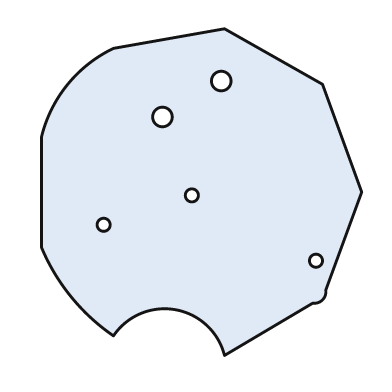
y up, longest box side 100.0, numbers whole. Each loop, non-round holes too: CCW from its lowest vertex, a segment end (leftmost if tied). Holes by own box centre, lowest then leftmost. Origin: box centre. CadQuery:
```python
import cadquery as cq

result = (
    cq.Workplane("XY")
    .moveTo(7.0, -50.0)
    .lineTo(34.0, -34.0)
    .threePointArc((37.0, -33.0), (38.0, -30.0))
    .lineTo(49.0, 0.0)
    .lineTo(37.0, 33.0)
    .lineTo(7.0, 50.0)
    .lineTo(-27.0, 44.0)
    .threePointArc((-41.0, 33.0), (-49.0, 17.0))
    .lineTo(-49.0, -17.0)
    .threePointArc((-40.0, -32.0), (-27.0, -44.0))
    .threePointArc((-8.0, -36.0), (7.0, -50.0))
    .close()
    .moveTo(35.0, -21.0)
    .circle(2.0)
    .moveTo(-30.0, -10.0)
    .circle(2.0)
    .moveTo(-3.0, -1.0)
    .circle(2.0)
    .moveTo(-12.0, 23.0)
    .circle(3.0)
    .moveTo(6.0, 34.0)
    .circle(3.0)
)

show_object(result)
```